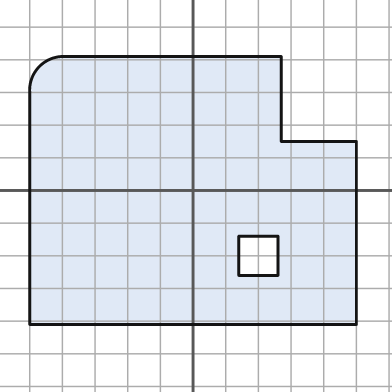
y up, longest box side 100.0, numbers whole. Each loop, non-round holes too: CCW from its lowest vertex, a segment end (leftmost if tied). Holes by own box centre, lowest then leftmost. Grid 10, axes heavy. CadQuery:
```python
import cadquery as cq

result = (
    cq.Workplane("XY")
    .moveTo(-50.0, -41.0)
    .lineTo(50.0, -41.0)
    .lineTo(50.0, 15.0)
    .lineTo(27.0, 15.0)
    .lineTo(27.0, 41.0)
    .lineTo(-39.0, 41.0)
    .threePointArc((-47.0, 38.0), (-50.0, 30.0))
    .close()
    .moveTo(14.0, -26.0)
    .lineTo(26.0, -26.0)
    .lineTo(26.0, -14.0)
    .lineTo(14.0, -14.0)
    .close()
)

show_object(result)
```